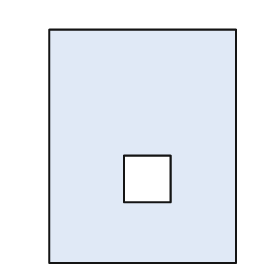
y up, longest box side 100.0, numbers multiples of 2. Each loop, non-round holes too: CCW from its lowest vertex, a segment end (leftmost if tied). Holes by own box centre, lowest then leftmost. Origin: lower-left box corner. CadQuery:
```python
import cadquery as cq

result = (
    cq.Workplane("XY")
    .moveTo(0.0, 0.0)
    .lineTo(80.0, 0.0)
    .lineTo(80.0, 100.0)
    .lineTo(0.0, 100.0)
    .close()
    .moveTo(32.0, 26.0)
    .lineTo(52.0, 26.0)
    .lineTo(52.0, 46.0)
    .lineTo(32.0, 46.0)
    .close()
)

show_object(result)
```